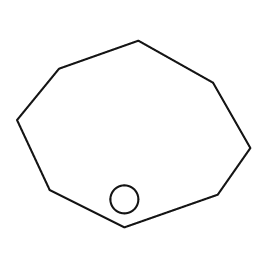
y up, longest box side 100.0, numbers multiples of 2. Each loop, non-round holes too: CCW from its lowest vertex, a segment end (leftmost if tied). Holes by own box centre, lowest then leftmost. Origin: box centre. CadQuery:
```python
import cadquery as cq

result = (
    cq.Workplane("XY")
    .moveTo(-4.0, -40.0)
    .lineTo(36.0, -26.0)
    .lineTo(50.0, -6.0)
    .lineTo(34.0, 22.0)
    .lineTo(2.0, 40.0)
    .lineTo(-32.0, 28.0)
    .lineTo(-50.0, 6.0)
    .lineTo(-36.0, -24.0)
    .close()
    .moveTo(-4.0, -28.0)
    .circle(6.0)
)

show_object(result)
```